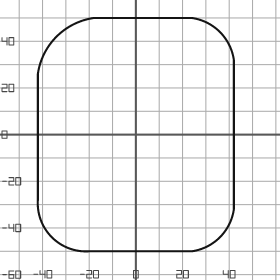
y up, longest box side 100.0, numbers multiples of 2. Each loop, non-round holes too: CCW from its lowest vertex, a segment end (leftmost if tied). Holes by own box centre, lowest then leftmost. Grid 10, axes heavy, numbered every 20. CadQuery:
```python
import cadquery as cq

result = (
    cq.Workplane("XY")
    .moveTo(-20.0, -50.0)
    .lineTo(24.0, -50.0)
    .threePointArc((36.0, -44.0), (42.0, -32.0))
    .lineTo(42.0, 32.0)
    .threePointArc((36.0, 44.0), (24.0, 50.0))
    .lineTo(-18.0, 50.0)
    .threePointArc((-34.0, 42.0), (-42.0, 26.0))
    .lineTo(-42.0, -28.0)
    .threePointArc((-36.0, -44.0), (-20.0, -50.0))
    .close()
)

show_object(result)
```